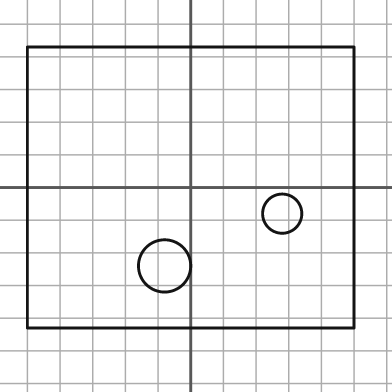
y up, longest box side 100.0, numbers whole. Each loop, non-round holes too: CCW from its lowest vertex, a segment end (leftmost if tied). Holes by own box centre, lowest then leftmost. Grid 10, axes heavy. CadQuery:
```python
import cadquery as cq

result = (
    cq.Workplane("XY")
    .moveTo(-50.0, -43.0)
    .lineTo(50.0, -43.0)
    .lineTo(50.0, 43.0)
    .lineTo(-50.0, 43.0)
    .close()
    .moveTo(-8.0, -24.0)
    .circle(8.0)
    .moveTo(28.0, -8.0)
    .circle(6.0)
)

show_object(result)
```